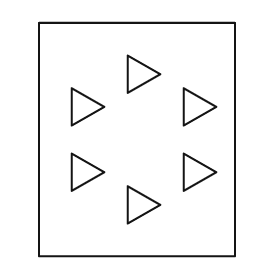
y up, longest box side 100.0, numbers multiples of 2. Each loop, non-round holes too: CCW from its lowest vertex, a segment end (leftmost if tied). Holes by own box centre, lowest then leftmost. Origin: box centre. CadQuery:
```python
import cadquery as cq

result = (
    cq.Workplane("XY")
    .moveTo(-42.0, -50.0)
    .lineTo(42.0, -50.0)
    .lineTo(42.0, 50.0)
    .lineTo(-42.0, 50.0)
    .close()
    .moveTo(-4.0, -36.0)
    .lineTo(10.0, -28.0)
    .lineTo(-4.0, -20.0)
    .close()
    .moveTo(-28.0, -22.0)
    .lineTo(-14.0, -14.0)
    .lineTo(-28.0, -6.0)
    .close()
    .moveTo(20.0, -22.0)
    .lineTo(34.0, -14.0)
    .lineTo(20.0, -6.0)
    .close()
    .moveTo(-28.0, 6.0)
    .lineTo(-14.0, 14.0)
    .lineTo(-28.0, 22.0)
    .close()
    .moveTo(20.0, 6.0)
    .lineTo(34.0, 14.0)
    .lineTo(20.0, 22.0)
    .close()
    .moveTo(-4.0, 20.0)
    .lineTo(10.0, 28.0)
    .lineTo(-4.0, 36.0)
    .close()
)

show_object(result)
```